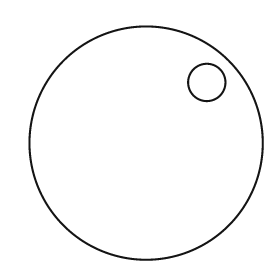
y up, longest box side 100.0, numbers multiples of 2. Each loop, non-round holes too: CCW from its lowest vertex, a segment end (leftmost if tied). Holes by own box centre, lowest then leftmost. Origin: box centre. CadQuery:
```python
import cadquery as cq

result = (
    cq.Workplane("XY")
    .moveTo(0.0, 0.0)
    .circle(50.0)
    .moveTo(26.0, 26.0)
    .circle(8.0)
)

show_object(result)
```